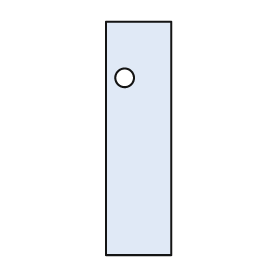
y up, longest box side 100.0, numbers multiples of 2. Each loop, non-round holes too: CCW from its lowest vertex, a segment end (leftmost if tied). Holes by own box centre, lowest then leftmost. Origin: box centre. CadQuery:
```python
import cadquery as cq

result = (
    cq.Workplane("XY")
    .moveTo(-14.0, -50.0)
    .lineTo(14.0, -50.0)
    .lineTo(14.0, 50.0)
    .lineTo(-14.0, 50.0)
    .close()
    .moveTo(-6.0, 26.0)
    .circle(4.0)
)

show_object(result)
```